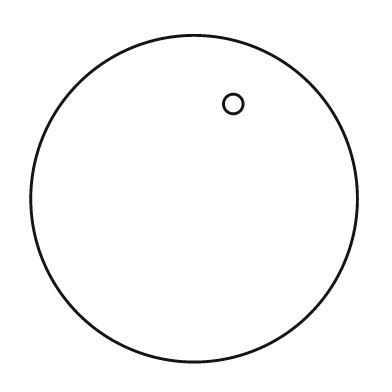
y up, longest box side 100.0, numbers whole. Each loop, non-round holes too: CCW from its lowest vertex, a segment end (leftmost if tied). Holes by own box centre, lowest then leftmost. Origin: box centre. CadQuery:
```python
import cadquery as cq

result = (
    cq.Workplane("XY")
    .moveTo(0.0, 0.0)
    .circle(50.0)
    .moveTo(12.0, 29.0)
    .circle(3.0)
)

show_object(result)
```